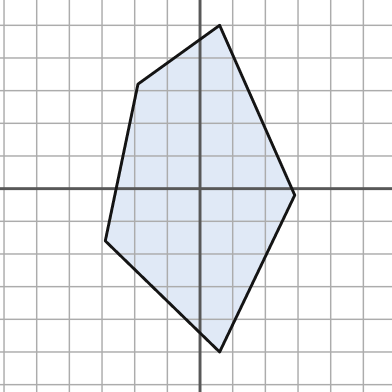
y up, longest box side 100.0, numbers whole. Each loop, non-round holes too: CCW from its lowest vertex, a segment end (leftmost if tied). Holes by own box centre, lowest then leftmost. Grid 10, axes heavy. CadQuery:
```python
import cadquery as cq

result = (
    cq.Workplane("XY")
    .moveTo(6.0, -50.0)
    .lineTo(29.0, -2.0)
    .lineTo(6.0, 50.0)
    .lineTo(-19.0, 32.0)
    .lineTo(-29.0, -16.0)
    .close()
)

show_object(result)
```